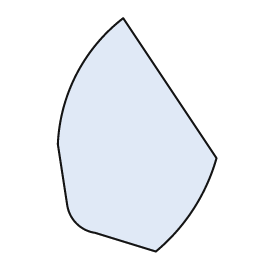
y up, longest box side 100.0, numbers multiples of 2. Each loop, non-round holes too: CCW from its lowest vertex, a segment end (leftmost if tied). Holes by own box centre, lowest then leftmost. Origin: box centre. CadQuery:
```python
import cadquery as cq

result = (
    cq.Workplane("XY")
    .moveTo(8.0, -50.0)
    .threePointArc((24.0, -32.0), (34.0, -10.0))
    .lineTo(-6.0, 50.0)
    .threePointArc((-26.0, 26.0), (-34.0, -4.0))
    .lineTo(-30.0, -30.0)
    .threePointArc((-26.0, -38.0), (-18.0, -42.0))
    .close()
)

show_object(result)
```